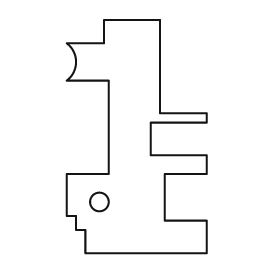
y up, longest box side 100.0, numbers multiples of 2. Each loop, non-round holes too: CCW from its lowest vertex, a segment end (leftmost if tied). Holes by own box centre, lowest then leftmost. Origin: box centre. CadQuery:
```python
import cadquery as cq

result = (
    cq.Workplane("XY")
    .moveTo(-22.0, -50.0)
    .lineTo(30.0, -50.0)
    .lineTo(30.0, -36.0)
    .lineTo(12.0, -36.0)
    .lineTo(12.0, -16.0)
    .lineTo(30.0, -16.0)
    .lineTo(30.0, -8.0)
    .lineTo(6.0, -8.0)
    .lineTo(6.0, 6.0)
    .lineTo(30.0, 6.0)
    .lineTo(30.0, 10.0)
    .lineTo(10.0, 10.0)
    .lineTo(10.0, 50.0)
    .lineTo(-14.0, 50.0)
    .lineTo(-14.0, 40.0)
    .lineTo(-30.0, 40.0)
    .threePointArc((-26.0, 32.0), (-30.0, 24.0))
    .lineTo(-12.0, 24.0)
    .lineTo(-12.0, -16.0)
    .lineTo(-30.0, -16.0)
    .lineTo(-30.0, -34.0)
    .lineTo(-26.0, -34.0)
    .lineTo(-26.0, -40.0)
    .lineTo(-22.0, -40.0)
    .close()
    .moveTo(-16.0, -28.0)
    .circle(4.0)
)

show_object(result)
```